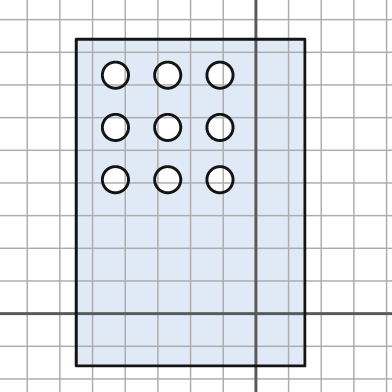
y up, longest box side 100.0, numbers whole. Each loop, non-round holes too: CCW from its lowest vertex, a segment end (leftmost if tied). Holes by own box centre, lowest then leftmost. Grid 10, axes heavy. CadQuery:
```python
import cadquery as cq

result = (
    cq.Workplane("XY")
    .moveTo(-55.0, -16.0)
    .lineTo(15.0, -16.0)
    .lineTo(15.0, 84.0)
    .lineTo(-55.0, 84.0)
    .close()
    .moveTo(-43.0, 41.0)
    .circle(4.0)
    .moveTo(-27.0, 41.0)
    .circle(4.0)
    .moveTo(-11.0, 41.0)
    .circle(4.0)
    .moveTo(-43.0, 57.0)
    .circle(4.0)
    .moveTo(-27.0, 57.0)
    .circle(4.0)
    .moveTo(-11.0, 57.0)
    .circle(4.0)
    .moveTo(-43.0, 73.0)
    .circle(4.0)
    .moveTo(-27.0, 73.0)
    .circle(4.0)
    .moveTo(-11.0, 73.0)
    .circle(4.0)
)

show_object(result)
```